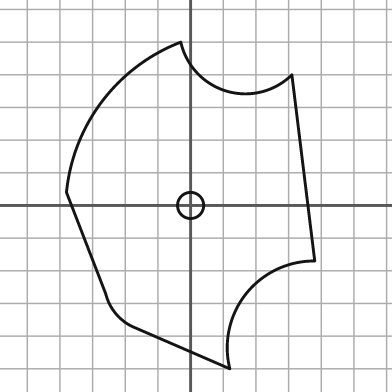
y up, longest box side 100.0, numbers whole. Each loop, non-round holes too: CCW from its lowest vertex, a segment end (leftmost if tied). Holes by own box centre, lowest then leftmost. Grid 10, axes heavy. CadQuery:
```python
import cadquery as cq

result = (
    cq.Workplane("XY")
    .moveTo(12.0, -50.0)
    .threePointArc((17.0, -27.0), (38.0, -17.0))
    .lineTo(31.0, 40.0)
    .threePointArc((11.0, 35.0), (-3.0, 50.0))
    .threePointArc((-27.0, 32.0), (-38.0, 4.0))
    .lineTo(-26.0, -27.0)
    .threePointArc((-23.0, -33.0), (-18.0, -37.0))
    .close()
    .moveTo(0.0, 0.0)
    .circle(4.0)
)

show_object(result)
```